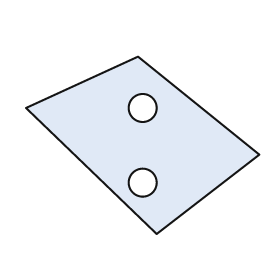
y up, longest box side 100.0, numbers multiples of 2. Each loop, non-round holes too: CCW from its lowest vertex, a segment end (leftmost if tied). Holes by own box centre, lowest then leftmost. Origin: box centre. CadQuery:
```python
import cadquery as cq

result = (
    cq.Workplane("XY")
    .moveTo(6.0, -38.0)
    .lineTo(50.0, -4.0)
    .lineTo(-2.0, 38.0)
    .lineTo(-50.0, 16.0)
    .close()
    .moveTo(0.0, -16.0)
    .circle(6.0)
    .moveTo(0.0, 16.0)
    .circle(6.0)
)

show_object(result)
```